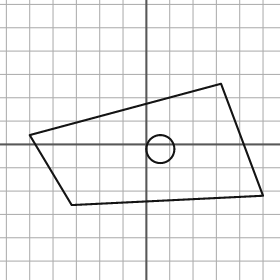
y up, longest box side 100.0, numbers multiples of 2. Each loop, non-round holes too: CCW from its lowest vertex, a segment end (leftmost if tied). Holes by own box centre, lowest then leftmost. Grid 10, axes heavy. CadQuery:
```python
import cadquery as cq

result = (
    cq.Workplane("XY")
    .moveTo(-32.0, -26.0)
    .lineTo(50.0, -22.0)
    .lineTo(32.0, 26.0)
    .lineTo(-50.0, 4.0)
    .close()
    .moveTo(6.0, -2.0)
    .circle(6.0)
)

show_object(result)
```